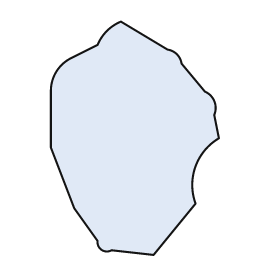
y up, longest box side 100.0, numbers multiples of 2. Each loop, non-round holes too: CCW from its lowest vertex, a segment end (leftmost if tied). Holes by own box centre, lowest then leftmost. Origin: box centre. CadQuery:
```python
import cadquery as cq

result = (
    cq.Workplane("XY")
    .moveTo(8.0, -50.0)
    .lineTo(26.0, -28.0)
    .threePointArc((26.0, -12.0), (36.0, 0.0))
    .lineTo(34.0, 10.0)
    .threePointArc((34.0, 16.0), (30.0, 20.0))
    .lineTo(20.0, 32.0)
    .threePointArc((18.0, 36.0), (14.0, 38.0))
    .lineTo(-6.0, 50.0)
    .threePointArc((-12.0, 46.0), (-16.0, 40.0))
    .lineTo(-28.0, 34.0)
    .threePointArc((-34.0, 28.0), (-36.0, 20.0))
    .lineTo(-36.0, -4.0)
    .lineTo(-26.0, -30.0)
    .lineTo(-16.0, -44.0)
    .threePointArc((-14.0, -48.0), (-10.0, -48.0))
    .close()
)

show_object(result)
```